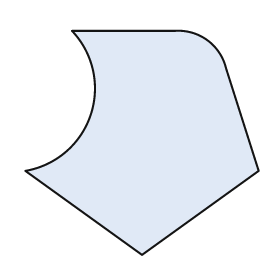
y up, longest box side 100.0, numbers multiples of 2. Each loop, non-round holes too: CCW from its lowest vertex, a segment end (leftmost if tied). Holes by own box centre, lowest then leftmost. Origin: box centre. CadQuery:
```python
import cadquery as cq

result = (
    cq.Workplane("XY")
    .moveTo(0.0, -48.0)
    .lineTo(50.0, -12.0)
    .lineTo(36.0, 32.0)
    .threePointArc((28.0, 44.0), (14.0, 48.0))
    .lineTo(-30.0, 48.0)
    .threePointArc((-22.0, 12.0), (-50.0, -12.0))
    .close()
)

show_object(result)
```